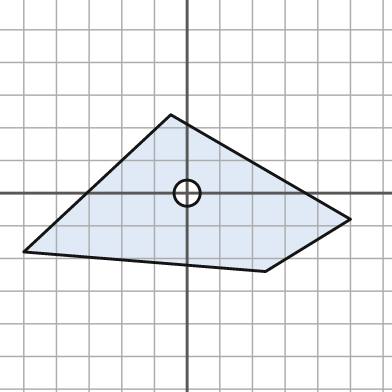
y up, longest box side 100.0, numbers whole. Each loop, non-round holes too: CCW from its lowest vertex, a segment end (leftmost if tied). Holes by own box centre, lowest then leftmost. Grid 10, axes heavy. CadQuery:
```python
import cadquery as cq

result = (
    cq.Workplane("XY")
    .moveTo(24.0, -24.0)
    .lineTo(50.0, -8.0)
    .lineTo(-5.0, 24.0)
    .lineTo(-50.0, -18.0)
    .close()
    .moveTo(0.0, 0.0)
    .circle(4.0)
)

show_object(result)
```